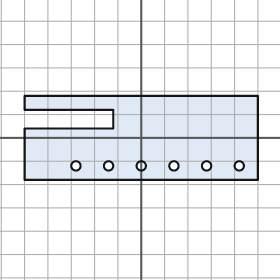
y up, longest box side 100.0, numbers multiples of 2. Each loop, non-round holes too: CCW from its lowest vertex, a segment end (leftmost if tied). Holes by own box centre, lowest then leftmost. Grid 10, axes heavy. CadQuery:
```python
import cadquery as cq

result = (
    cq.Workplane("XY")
    .moveTo(-50.0, -18.0)
    .lineTo(50.0, -18.0)
    .lineTo(50.0, 18.0)
    .lineTo(-50.0, 18.0)
    .lineTo(-50.0, 12.0)
    .lineTo(-12.0, 12.0)
    .lineTo(-12.0, 4.0)
    .lineTo(-50.0, 4.0)
    .close()
    .moveTo(-28.0, -12.0)
    .circle(2.0)
    .moveTo(-14.0, -12.0)
    .circle(2.0)
    .moveTo(0.0, -12.0)
    .circle(2.0)
    .moveTo(14.0, -12.0)
    .circle(2.0)
    .moveTo(28.0, -12.0)
    .circle(2.0)
    .moveTo(42.0, -12.0)
    .circle(2.0)
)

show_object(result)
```